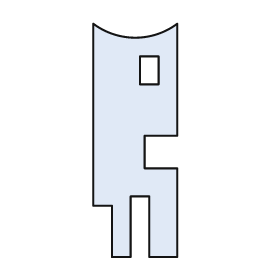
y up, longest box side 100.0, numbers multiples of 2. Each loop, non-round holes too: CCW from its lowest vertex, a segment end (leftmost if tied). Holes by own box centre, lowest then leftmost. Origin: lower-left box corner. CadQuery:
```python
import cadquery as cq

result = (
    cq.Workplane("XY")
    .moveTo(8.0, 0.0)
    .lineTo(16.0, 0.0)
    .lineTo(16.0, 26.0)
    .lineTo(24.0, 26.0)
    .lineTo(24.0, 0.0)
    .lineTo(36.0, 0.0)
    .lineTo(36.0, 38.0)
    .lineTo(22.0, 38.0)
    .lineTo(22.0, 52.0)
    .lineTo(36.0, 52.0)
    .lineTo(36.0, 100.0)
    .threePointArc((18.0, 94.0), (0.0, 100.0))
    .lineTo(0.0, 22.0)
    .lineTo(8.0, 22.0)
    .close()
    .moveTo(20.0, 74.0)
    .lineTo(28.0, 74.0)
    .lineTo(28.0, 86.0)
    .lineTo(20.0, 86.0)
    .close()
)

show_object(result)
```